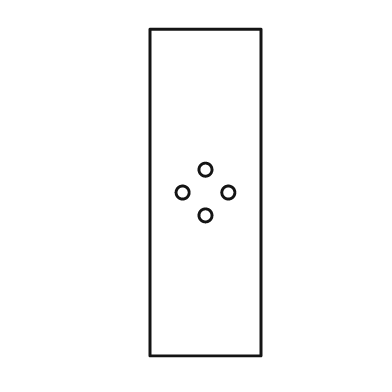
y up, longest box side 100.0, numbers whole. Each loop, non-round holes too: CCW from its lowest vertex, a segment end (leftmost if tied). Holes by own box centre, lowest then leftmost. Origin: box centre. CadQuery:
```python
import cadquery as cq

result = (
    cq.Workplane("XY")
    .moveTo(-17.0, -50.0)
    .lineTo(17.0, -50.0)
    .lineTo(17.0, 50.0)
    .lineTo(-17.0, 50.0)
    .close()
    .moveTo(0.0, -7.0)
    .circle(2.0)
    .moveTo(-7.0, 0.0)
    .circle(2.0)
    .moveTo(7.0, 0.0)
    .circle(2.0)
    .moveTo(0.0, 7.0)
    .circle(2.0)
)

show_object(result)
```